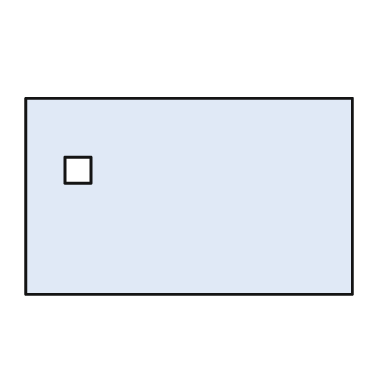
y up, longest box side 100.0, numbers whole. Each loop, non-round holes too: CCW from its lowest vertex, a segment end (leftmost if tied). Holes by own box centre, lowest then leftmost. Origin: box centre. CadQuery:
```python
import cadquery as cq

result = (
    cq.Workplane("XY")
    .moveTo(-50.0, -30.0)
    .lineTo(50.0, -30.0)
    .lineTo(50.0, 30.0)
    .lineTo(-50.0, 30.0)
    .close()
    .moveTo(-38.0, 4.0)
    .lineTo(-30.0, 4.0)
    .lineTo(-30.0, 12.0)
    .lineTo(-38.0, 12.0)
    .close()
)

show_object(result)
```